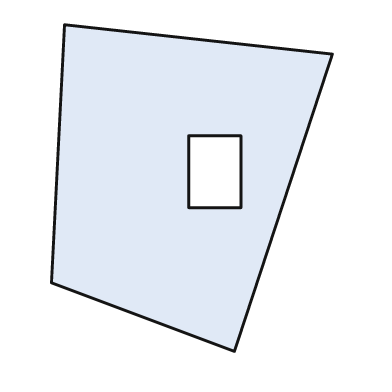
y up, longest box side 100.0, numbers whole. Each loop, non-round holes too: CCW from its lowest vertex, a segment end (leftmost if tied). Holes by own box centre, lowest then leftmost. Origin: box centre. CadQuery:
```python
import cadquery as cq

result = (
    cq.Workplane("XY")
    .moveTo(13.0, -50.0)
    .lineTo(43.0, 41.0)
    .lineTo(-39.0, 50.0)
    .lineTo(-43.0, -29.0)
    .close()
    .moveTo(-1.0, -6.0)
    .lineTo(15.0, -6.0)
    .lineTo(15.0, 16.0)
    .lineTo(-1.0, 16.0)
    .close()
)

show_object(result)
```